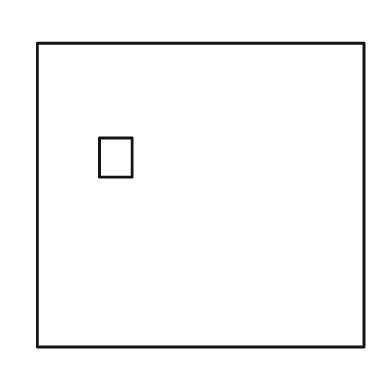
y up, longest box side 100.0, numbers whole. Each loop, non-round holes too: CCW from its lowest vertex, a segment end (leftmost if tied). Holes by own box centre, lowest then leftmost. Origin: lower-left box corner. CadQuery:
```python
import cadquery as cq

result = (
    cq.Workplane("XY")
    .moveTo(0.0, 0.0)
    .lineTo(100.0, 0.0)
    .lineTo(100.0, 93.0)
    .lineTo(0.0, 93.0)
    .close()
    .moveTo(19.0, 52.0)
    .lineTo(29.0, 52.0)
    .lineTo(29.0, 64.0)
    .lineTo(19.0, 64.0)
    .close()
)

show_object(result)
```